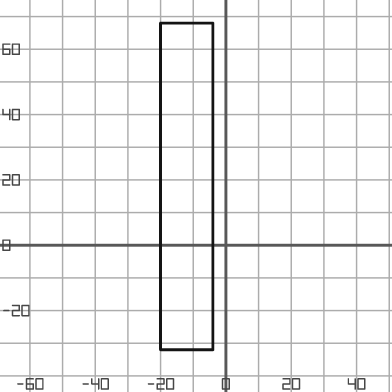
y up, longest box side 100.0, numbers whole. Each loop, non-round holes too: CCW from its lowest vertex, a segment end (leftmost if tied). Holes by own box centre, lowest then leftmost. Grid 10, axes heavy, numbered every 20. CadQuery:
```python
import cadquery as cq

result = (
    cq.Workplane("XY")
    .moveTo(-20.0, -32.0)
    .lineTo(-4.0, -32.0)
    .lineTo(-4.0, 68.0)
    .lineTo(-20.0, 68.0)
    .close()
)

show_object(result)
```